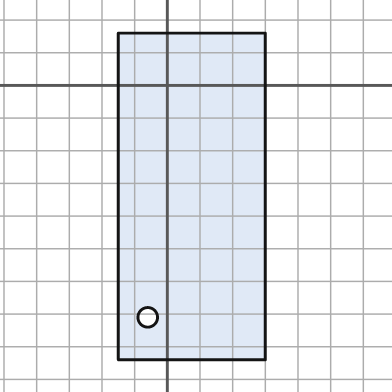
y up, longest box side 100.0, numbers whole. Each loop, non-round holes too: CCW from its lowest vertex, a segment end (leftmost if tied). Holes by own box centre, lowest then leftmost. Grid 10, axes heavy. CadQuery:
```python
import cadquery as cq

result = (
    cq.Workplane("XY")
    .moveTo(-15.0, -84.0)
    .lineTo(30.0, -84.0)
    .lineTo(30.0, 16.0)
    .lineTo(-15.0, 16.0)
    .close()
    .moveTo(-6.0, -71.0)
    .circle(3.0)
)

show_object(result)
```